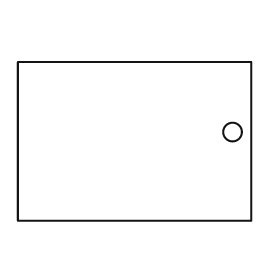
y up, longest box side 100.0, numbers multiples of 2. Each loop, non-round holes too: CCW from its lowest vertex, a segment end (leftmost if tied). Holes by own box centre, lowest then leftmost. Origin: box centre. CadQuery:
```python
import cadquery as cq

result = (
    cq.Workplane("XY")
    .moveTo(-50.0, -34.0)
    .lineTo(50.0, -34.0)
    .lineTo(50.0, 34.0)
    .lineTo(-50.0, 34.0)
    .close()
    .moveTo(42.0, 4.0)
    .circle(4.0)
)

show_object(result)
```